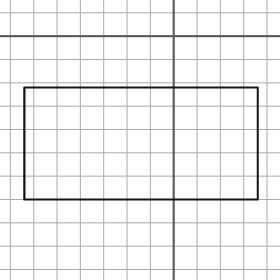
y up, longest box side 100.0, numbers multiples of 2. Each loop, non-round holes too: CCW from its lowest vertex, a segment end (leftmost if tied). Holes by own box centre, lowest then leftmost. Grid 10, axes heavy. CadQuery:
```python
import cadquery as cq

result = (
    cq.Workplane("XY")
    .moveTo(-64.0, -70.0)
    .lineTo(36.0, -70.0)
    .lineTo(36.0, -22.0)
    .lineTo(-64.0, -22.0)
    .close()
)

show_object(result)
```